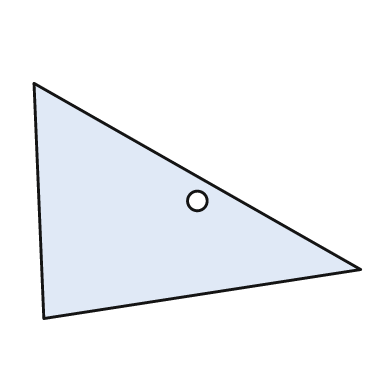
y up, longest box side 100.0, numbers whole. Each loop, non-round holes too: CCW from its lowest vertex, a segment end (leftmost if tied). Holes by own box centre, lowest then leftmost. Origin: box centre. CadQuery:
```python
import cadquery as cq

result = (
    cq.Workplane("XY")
    .moveTo(-47.0, -36.0)
    .lineTo(50.0, -21.0)
    .lineTo(-50.0, 36.0)
    .close()
    .moveTo(0.0, 0.0)
    .circle(3.0)
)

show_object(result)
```